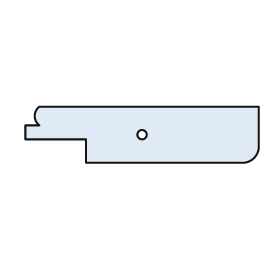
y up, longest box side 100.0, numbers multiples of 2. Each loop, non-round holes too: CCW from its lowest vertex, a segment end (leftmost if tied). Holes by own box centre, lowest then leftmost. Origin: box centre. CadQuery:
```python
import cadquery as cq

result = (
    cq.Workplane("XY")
    .moveTo(-24.0, -12.0)
    .lineTo(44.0, -12.0)
    .threePointArc((48.0, -10.0), (50.0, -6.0))
    .lineTo(50.0, 12.0)
    .lineTo(-44.0, 12.0)
    .threePointArc((-46.0, 8.0), (-44.0, 4.0))
    .lineTo(-50.0, 4.0)
    .lineTo(-50.0, -2.0)
    .lineTo(-24.0, -2.0)
    .close()
    .moveTo(0.0, 0.0)
    .circle(2.0)
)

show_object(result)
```